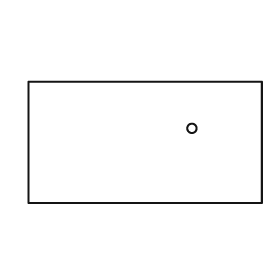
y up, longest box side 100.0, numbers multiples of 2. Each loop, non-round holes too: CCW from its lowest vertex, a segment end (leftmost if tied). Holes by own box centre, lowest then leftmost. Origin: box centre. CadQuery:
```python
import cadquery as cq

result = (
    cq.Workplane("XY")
    .moveTo(-50.0, -26.0)
    .lineTo(50.0, -26.0)
    .lineTo(50.0, 26.0)
    .lineTo(-50.0, 26.0)
    .close()
    .moveTo(20.0, 6.0)
    .circle(2.0)
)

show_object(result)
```